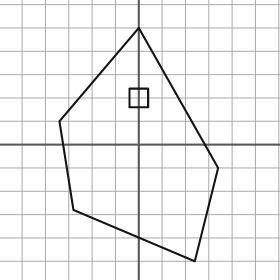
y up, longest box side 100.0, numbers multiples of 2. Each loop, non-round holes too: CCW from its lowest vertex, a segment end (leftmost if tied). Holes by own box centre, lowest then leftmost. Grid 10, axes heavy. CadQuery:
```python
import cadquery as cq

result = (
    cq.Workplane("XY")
    .moveTo(24.0, -50.0)
    .lineTo(34.0, -10.0)
    .lineTo(0.0, 50.0)
    .lineTo(-34.0, 10.0)
    .lineTo(-28.0, -28.0)
    .close()
    .moveTo(-4.0, 16.0)
    .lineTo(4.0, 16.0)
    .lineTo(4.0, 24.0)
    .lineTo(-4.0, 24.0)
    .close()
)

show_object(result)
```